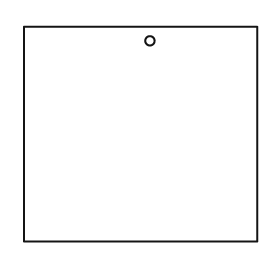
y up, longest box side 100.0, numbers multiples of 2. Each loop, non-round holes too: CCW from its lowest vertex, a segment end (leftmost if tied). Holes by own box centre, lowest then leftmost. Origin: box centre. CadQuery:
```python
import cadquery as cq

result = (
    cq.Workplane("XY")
    .moveTo(-50.0, -46.0)
    .lineTo(50.0, -46.0)
    .lineTo(50.0, 46.0)
    .lineTo(-50.0, 46.0)
    .close()
    .moveTo(4.0, 40.0)
    .circle(2.0)
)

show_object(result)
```